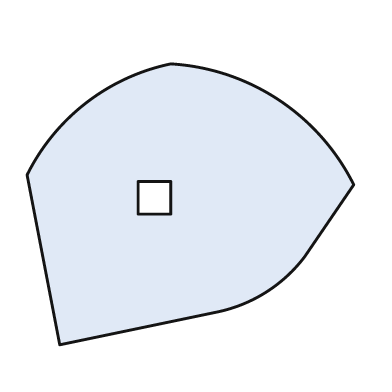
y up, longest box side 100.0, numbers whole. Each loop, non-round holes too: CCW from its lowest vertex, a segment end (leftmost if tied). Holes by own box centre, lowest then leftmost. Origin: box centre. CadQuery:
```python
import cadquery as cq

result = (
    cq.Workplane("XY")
    .moveTo(-40.0, -43.0)
    .lineTo(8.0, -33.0)
    .threePointArc((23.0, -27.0), (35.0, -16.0))
    .lineTo(50.0, 6.0)
    .threePointArc((27.0, 32.0), (-6.0, 43.0))
    .threePointArc((-32.0, 31.0), (-50.0, 9.0))
    .close()
    .moveTo(-16.0, -3.0)
    .lineTo(-6.0, -3.0)
    .lineTo(-6.0, 7.0)
    .lineTo(-16.0, 7.0)
    .close()
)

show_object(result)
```